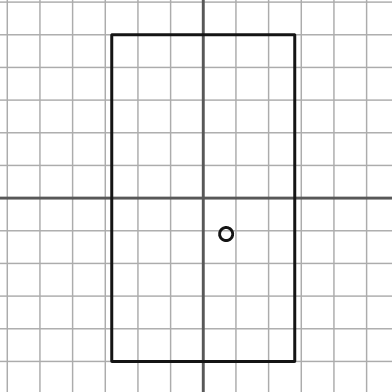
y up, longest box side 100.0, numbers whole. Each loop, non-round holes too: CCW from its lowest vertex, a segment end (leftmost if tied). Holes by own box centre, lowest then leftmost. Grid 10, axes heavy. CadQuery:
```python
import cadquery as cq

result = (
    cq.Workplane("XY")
    .moveTo(-28.0, -50.0)
    .lineTo(28.0, -50.0)
    .lineTo(28.0, 50.0)
    .lineTo(-28.0, 50.0)
    .close()
    .moveTo(7.0, -11.0)
    .circle(2.0)
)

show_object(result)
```